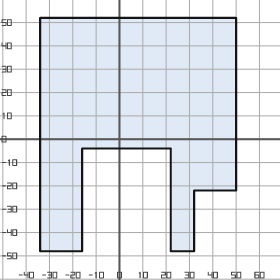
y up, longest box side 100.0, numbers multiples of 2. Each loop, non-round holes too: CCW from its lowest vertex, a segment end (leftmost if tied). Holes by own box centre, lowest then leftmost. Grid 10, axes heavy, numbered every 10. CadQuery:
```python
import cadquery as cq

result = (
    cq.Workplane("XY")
    .moveTo(-34.0, -48.0)
    .lineTo(-16.0, -48.0)
    .lineTo(-16.0, -4.0)
    .lineTo(22.0, -4.0)
    .lineTo(22.0, -48.0)
    .lineTo(32.0, -48.0)
    .lineTo(32.0, -22.0)
    .lineTo(50.0, -22.0)
    .lineTo(50.0, 52.0)
    .lineTo(-34.0, 52.0)
    .close()
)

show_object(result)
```